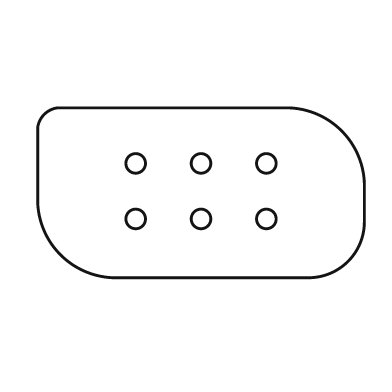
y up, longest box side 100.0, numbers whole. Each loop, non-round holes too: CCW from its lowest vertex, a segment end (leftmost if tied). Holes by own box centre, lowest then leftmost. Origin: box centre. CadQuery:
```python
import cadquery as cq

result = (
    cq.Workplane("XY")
    .moveTo(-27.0, -26.0)
    .lineTo(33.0, -26.0)
    .threePointArc((45.0, -21.0), (50.0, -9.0))
    .lineTo(50.0, 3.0)
    .threePointArc((43.0, 19.0), (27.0, 26.0))
    .lineTo(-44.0, 26.0)
    .threePointArc((-48.0, 24.0), (-50.0, 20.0))
    .lineTo(-50.0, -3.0)
    .threePointArc((-43.0, -19.0), (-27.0, -26.0))
    .close()
    .moveTo(-20.0, -8.0)
    .circle(3.0)
    .moveTo(0.0, -8.0)
    .circle(3.0)
    .moveTo(20.0, -8.0)
    .circle(3.0)
    .moveTo(-20.0, 9.0)
    .circle(3.0)
    .moveTo(0.0, 9.0)
    .circle(3.0)
    .moveTo(20.0, 9.0)
    .circle(3.0)
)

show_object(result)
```